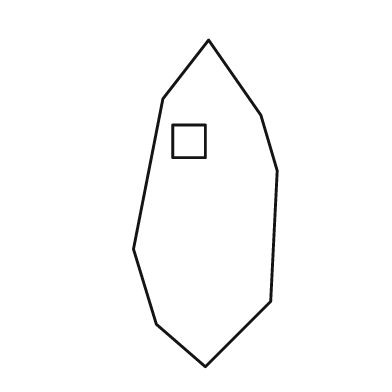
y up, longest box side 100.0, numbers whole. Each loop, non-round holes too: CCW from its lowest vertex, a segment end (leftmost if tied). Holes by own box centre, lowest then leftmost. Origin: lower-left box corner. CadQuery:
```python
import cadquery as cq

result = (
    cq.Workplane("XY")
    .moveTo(22.0, 0.0)
    .lineTo(42.0, 20.0)
    .lineTo(44.0, 60.0)
    .lineTo(39.0, 77.0)
    .lineTo(23.0, 100.0)
    .lineTo(9.0, 82.0)
    .lineTo(0.0, 36.0)
    .lineTo(7.0, 13.0)
    .close()
    .moveTo(12.0, 64.0)
    .lineTo(22.0, 64.0)
    .lineTo(22.0, 74.0)
    .lineTo(12.0, 74.0)
    .close()
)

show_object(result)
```